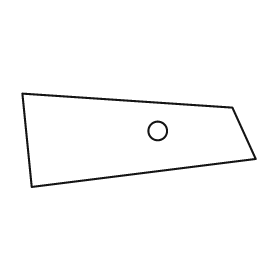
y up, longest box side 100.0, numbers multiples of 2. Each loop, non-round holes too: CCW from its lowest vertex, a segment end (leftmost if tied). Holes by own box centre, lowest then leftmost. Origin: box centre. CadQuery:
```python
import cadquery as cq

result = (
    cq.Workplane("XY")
    .moveTo(-46.0, -20.0)
    .lineTo(50.0, -8.0)
    .lineTo(40.0, 14.0)
    .lineTo(-50.0, 20.0)
    .close()
    .moveTo(8.0, 4.0)
    .circle(4.0)
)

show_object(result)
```